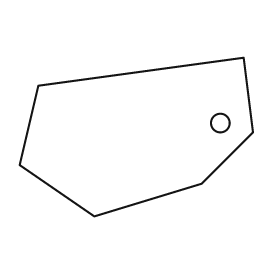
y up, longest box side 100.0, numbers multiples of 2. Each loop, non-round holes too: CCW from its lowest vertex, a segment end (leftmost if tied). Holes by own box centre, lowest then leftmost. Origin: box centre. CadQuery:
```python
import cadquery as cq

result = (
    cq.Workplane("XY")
    .moveTo(-18.0, -34.0)
    .lineTo(28.0, -20.0)
    .lineTo(50.0, 2.0)
    .lineTo(46.0, 34.0)
    .lineTo(-42.0, 22.0)
    .lineTo(-50.0, -12.0)
    .close()
    .moveTo(36.0, 6.0)
    .circle(4.0)
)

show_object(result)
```